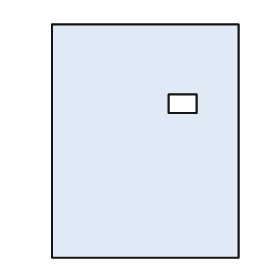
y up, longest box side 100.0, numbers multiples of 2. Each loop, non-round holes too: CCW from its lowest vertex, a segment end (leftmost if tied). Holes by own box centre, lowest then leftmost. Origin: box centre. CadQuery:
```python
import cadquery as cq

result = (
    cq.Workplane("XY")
    .moveTo(-40.0, -50.0)
    .lineTo(40.0, -50.0)
    .lineTo(40.0, 50.0)
    .lineTo(-40.0, 50.0)
    .close()
    .moveTo(10.0, 12.0)
    .lineTo(22.0, 12.0)
    .lineTo(22.0, 20.0)
    .lineTo(10.0, 20.0)
    .close()
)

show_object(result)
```